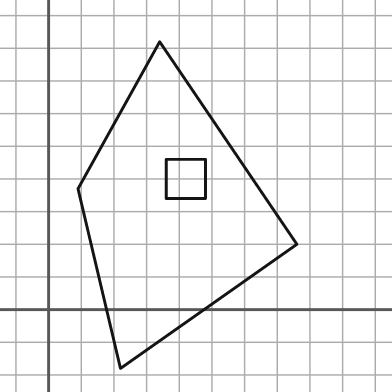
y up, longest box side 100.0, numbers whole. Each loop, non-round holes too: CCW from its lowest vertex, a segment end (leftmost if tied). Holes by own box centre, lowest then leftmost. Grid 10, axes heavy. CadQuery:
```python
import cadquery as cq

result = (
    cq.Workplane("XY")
    .moveTo(22.0, -18.0)
    .lineTo(76.0, 20.0)
    .lineTo(34.0, 82.0)
    .lineTo(9.0, 37.0)
    .close()
    .moveTo(36.0, 34.0)
    .lineTo(48.0, 34.0)
    .lineTo(48.0, 46.0)
    .lineTo(36.0, 46.0)
    .close()
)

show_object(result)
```